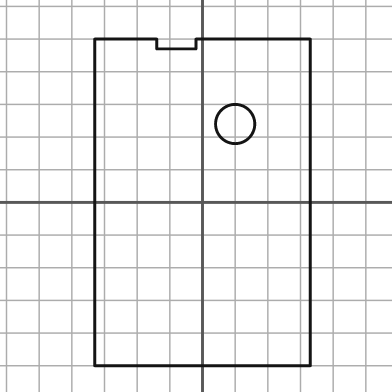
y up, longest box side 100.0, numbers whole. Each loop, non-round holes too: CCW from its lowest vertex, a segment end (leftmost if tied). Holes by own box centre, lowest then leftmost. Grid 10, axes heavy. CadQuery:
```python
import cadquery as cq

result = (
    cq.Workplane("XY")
    .moveTo(-33.0, -50.0)
    .lineTo(33.0, -50.0)
    .lineTo(33.0, 50.0)
    .lineTo(-2.0, 50.0)
    .lineTo(-2.0, 47.0)
    .lineTo(-14.0, 47.0)
    .lineTo(-14.0, 50.0)
    .lineTo(-33.0, 50.0)
    .close()
    .moveTo(10.0, 24.0)
    .circle(6.0)
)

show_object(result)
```